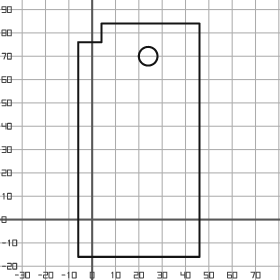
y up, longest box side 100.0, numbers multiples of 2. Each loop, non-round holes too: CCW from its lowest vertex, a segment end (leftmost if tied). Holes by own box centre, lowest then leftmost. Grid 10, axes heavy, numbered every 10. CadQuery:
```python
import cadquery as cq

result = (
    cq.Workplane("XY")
    .moveTo(-6.0, -16.0)
    .lineTo(46.0, -16.0)
    .lineTo(46.0, 84.0)
    .lineTo(4.0, 84.0)
    .lineTo(4.0, 76.0)
    .lineTo(-6.0, 76.0)
    .close()
    .moveTo(24.0, 70.0)
    .circle(4.0)
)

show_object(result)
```